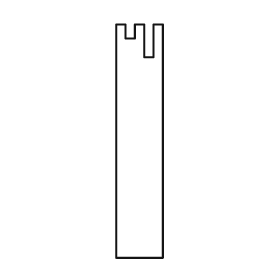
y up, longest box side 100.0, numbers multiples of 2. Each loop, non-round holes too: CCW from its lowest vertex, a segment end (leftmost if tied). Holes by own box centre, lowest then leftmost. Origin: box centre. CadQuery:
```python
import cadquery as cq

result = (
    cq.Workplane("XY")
    .moveTo(-10.0, -50.0)
    .lineTo(10.0, -50.0)
    .lineTo(10.0, 50.0)
    .lineTo(6.0, 50.0)
    .lineTo(6.0, 36.0)
    .lineTo(2.0, 36.0)
    .lineTo(2.0, 50.0)
    .lineTo(-2.0, 50.0)
    .lineTo(-2.0, 44.0)
    .lineTo(-6.0, 44.0)
    .lineTo(-6.0, 50.0)
    .lineTo(-10.0, 50.0)
    .close()
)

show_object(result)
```